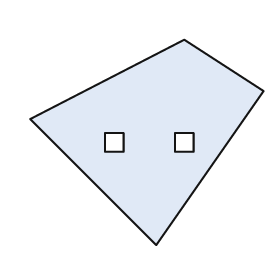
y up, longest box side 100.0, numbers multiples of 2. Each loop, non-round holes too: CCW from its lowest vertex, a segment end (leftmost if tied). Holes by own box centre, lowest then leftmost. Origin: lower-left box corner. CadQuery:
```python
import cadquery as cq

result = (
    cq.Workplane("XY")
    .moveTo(54.0, 0.0)
    .lineTo(100.0, 66.0)
    .lineTo(66.0, 88.0)
    .lineTo(0.0, 54.0)
    .close()
    .moveTo(32.0, 40.0)
    .lineTo(40.0, 40.0)
    .lineTo(40.0, 48.0)
    .lineTo(32.0, 48.0)
    .close()
    .moveTo(62.0, 40.0)
    .lineTo(70.0, 40.0)
    .lineTo(70.0, 48.0)
    .lineTo(62.0, 48.0)
    .close()
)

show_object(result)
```